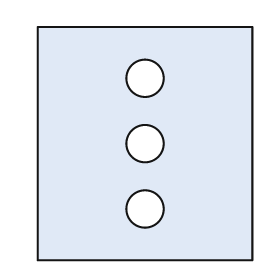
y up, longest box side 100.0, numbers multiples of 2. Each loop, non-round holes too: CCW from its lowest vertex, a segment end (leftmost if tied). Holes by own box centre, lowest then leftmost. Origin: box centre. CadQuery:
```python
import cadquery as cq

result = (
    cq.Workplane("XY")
    .moveTo(-46.0, -50.0)
    .lineTo(46.0, -50.0)
    .lineTo(46.0, 50.0)
    .lineTo(-46.0, 50.0)
    .close()
    .moveTo(0.0, -28.0)
    .circle(8.0)
    .moveTo(0.0, 0.0)
    .circle(8.0)
    .moveTo(0.0, 28.0)
    .circle(8.0)
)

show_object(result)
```